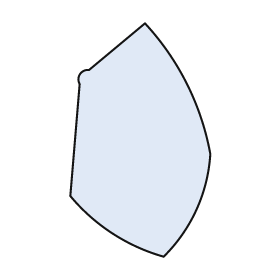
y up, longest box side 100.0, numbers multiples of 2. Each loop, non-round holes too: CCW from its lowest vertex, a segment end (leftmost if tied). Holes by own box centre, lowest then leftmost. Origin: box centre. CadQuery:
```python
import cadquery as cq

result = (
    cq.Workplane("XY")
    .moveTo(10.0, -50.0)
    .threePointArc((24.0, -30.0), (30.0, -6.0))
    .threePointArc((20.0, 24.0), (2.0, 50.0))
    .lineTo(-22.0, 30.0)
    .threePointArc((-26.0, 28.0), (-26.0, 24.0))
    .lineTo(-30.0, -24.0)
    .threePointArc((-12.0, -40.0), (10.0, -50.0))
    .close()
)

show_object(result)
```